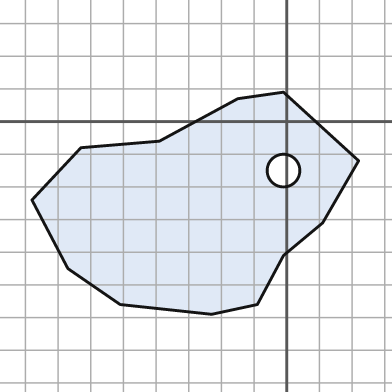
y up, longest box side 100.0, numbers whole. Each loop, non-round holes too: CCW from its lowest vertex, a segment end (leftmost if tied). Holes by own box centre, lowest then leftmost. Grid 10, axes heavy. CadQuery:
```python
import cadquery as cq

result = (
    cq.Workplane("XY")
    .moveTo(-23.0, -59.0)
    .lineTo(-9.0, -56.0)
    .lineTo(-1.0, -41.0)
    .lineTo(11.0, -31.0)
    .lineTo(22.0, -12.0)
    .lineTo(-1.0, 9.0)
    .lineTo(-15.0, 7.0)
    .lineTo(-39.0, -6.0)
    .lineTo(-63.0, -8.0)
    .lineTo(-78.0, -24.0)
    .lineTo(-67.0, -45.0)
    .lineTo(-51.0, -56.0)
    .close()
    .moveTo(-1.0, -15.0)
    .circle(5.0)
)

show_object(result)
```